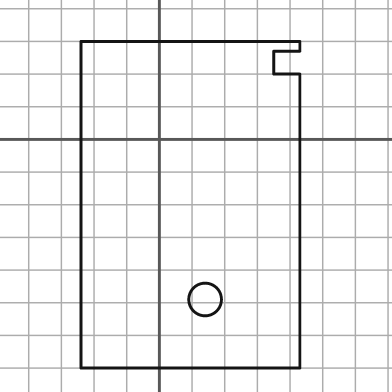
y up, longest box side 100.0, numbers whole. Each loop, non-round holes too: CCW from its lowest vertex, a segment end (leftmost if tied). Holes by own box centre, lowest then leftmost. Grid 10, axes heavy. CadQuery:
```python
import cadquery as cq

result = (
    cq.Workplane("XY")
    .moveTo(-24.0, -70.0)
    .lineTo(43.0, -70.0)
    .lineTo(43.0, 20.0)
    .lineTo(35.0, 20.0)
    .lineTo(35.0, 27.0)
    .lineTo(43.0, 27.0)
    .lineTo(43.0, 30.0)
    .lineTo(-24.0, 30.0)
    .close()
    .moveTo(14.0, -49.0)
    .circle(5.0)
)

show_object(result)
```